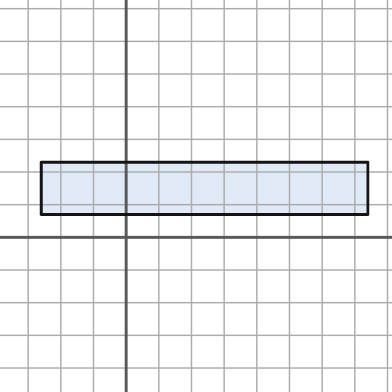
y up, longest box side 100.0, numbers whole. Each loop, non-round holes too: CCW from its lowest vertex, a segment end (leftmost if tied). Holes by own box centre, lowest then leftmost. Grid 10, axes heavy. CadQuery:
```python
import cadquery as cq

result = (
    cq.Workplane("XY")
    .moveTo(-26.0, 7.0)
    .lineTo(74.0, 7.0)
    .lineTo(74.0, 23.0)
    .lineTo(-26.0, 23.0)
    .close()
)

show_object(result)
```